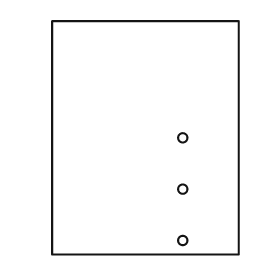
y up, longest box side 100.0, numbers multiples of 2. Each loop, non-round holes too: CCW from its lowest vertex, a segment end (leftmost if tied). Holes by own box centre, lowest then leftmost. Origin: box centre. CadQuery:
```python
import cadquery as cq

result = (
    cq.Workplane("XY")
    .moveTo(-40.0, -50.0)
    .lineTo(40.0, -50.0)
    .lineTo(40.0, 50.0)
    .lineTo(-40.0, 50.0)
    .close()
    .moveTo(16.0, -44.0)
    .circle(2.0)
    .moveTo(16.0, -22.0)
    .circle(2.0)
    .moveTo(16.0, 0.0)
    .circle(2.0)
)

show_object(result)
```